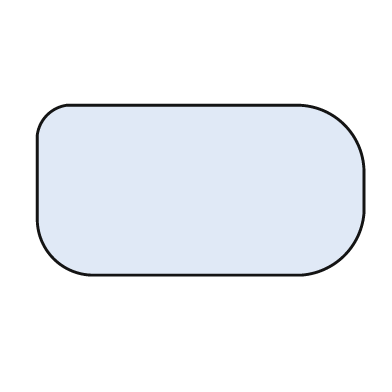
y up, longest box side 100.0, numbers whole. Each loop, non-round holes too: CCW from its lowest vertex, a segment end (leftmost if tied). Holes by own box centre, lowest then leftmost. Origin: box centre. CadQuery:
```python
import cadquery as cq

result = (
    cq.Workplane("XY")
    .moveTo(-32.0, -26.0)
    .lineTo(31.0, -26.0)
    .threePointArc((44.0, -20.0), (50.0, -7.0))
    .lineTo(50.0, 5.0)
    .threePointArc((44.0, 20.0), (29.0, 26.0))
    .lineTo(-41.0, 26.0)
    .threePointArc((-47.0, 23.0), (-50.0, 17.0))
    .lineTo(-50.0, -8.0)
    .threePointArc((-45.0, -21.0), (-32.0, -26.0))
    .close()
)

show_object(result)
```